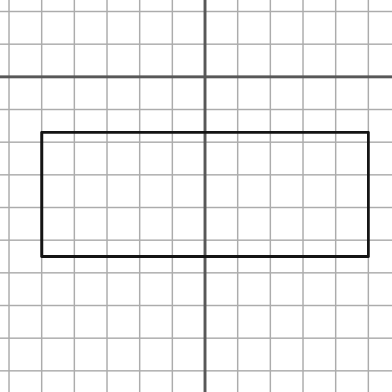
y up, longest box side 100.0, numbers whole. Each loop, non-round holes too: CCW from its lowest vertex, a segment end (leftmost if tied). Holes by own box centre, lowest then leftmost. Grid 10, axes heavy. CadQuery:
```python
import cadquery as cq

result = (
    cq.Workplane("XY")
    .moveTo(-50.0, -55.0)
    .lineTo(50.0, -55.0)
    .lineTo(50.0, -17.0)
    .lineTo(-50.0, -17.0)
    .close()
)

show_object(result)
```